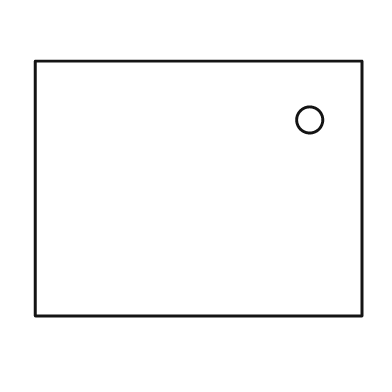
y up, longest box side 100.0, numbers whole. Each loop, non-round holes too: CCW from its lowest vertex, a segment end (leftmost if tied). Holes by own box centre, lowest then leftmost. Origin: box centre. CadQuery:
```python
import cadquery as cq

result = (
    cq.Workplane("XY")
    .moveTo(-50.0, -39.0)
    .lineTo(50.0, -39.0)
    .lineTo(50.0, 39.0)
    .lineTo(-50.0, 39.0)
    .close()
    .moveTo(34.0, 21.0)
    .circle(4.0)
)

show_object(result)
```